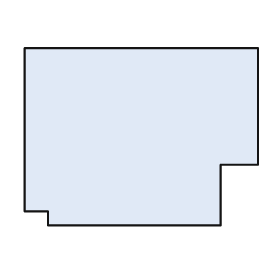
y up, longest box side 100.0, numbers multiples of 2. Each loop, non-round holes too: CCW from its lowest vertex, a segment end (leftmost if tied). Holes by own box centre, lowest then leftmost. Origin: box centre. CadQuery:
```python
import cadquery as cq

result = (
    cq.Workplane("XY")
    .moveTo(-40.0, -38.0)
    .lineTo(34.0, -38.0)
    .lineTo(34.0, -12.0)
    .lineTo(50.0, -12.0)
    .lineTo(50.0, 38.0)
    .lineTo(-50.0, 38.0)
    .lineTo(-50.0, -32.0)
    .lineTo(-40.0, -32.0)
    .close()
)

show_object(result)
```